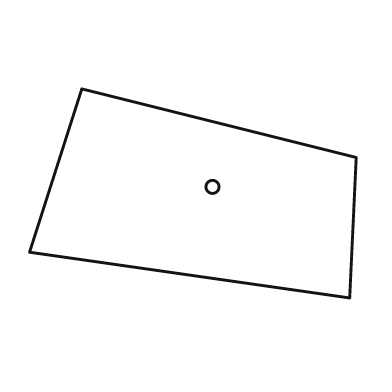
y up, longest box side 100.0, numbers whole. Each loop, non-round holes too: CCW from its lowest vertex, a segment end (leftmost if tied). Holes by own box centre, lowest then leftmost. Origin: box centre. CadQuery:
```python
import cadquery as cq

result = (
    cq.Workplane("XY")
    .moveTo(48.0, -32.0)
    .lineTo(50.0, 11.0)
    .lineTo(-34.0, 32.0)
    .lineTo(-50.0, -18.0)
    .close()
    .moveTo(6.0, 2.0)
    .circle(2.0)
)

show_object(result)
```